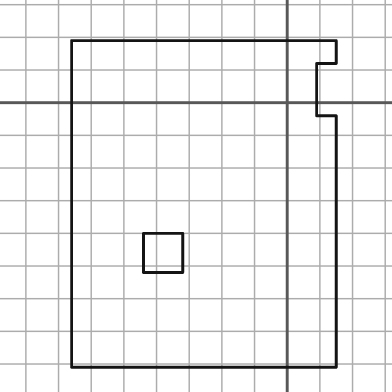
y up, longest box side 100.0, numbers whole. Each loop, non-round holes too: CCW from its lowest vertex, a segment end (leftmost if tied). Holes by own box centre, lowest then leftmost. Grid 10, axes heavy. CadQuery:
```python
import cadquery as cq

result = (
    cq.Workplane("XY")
    .moveTo(-66.0, -81.0)
    .lineTo(15.0, -81.0)
    .lineTo(15.0, -4.0)
    .lineTo(9.0, -4.0)
    .lineTo(9.0, 12.0)
    .lineTo(15.0, 12.0)
    .lineTo(15.0, 19.0)
    .lineTo(-66.0, 19.0)
    .close()
    .moveTo(-44.0, -52.0)
    .lineTo(-32.0, -52.0)
    .lineTo(-32.0, -40.0)
    .lineTo(-44.0, -40.0)
    .close()
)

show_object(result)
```